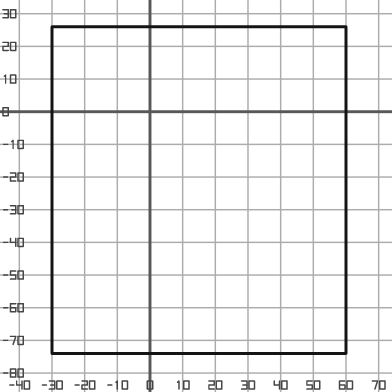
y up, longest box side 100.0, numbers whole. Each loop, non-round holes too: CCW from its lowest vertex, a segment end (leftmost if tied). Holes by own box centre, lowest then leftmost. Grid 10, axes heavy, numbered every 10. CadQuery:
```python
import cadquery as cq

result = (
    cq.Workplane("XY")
    .moveTo(-30.0, -74.0)
    .lineTo(60.0, -74.0)
    .lineTo(60.0, 26.0)
    .lineTo(-30.0, 26.0)
    .close()
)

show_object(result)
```